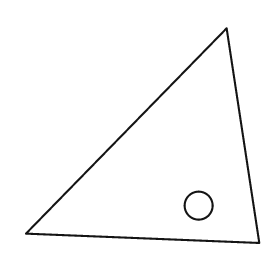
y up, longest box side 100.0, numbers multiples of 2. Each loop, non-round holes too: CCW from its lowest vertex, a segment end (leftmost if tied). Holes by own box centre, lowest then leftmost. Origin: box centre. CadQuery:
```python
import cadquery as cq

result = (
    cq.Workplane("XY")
    .moveTo(50.0, -46.0)
    .lineTo(36.0, 46.0)
    .lineTo(-50.0, -42.0)
    .close()
    .moveTo(24.0, -30.0)
    .circle(6.0)
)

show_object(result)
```